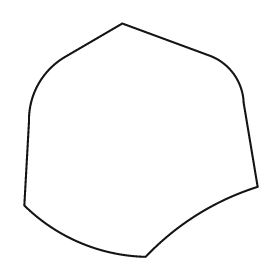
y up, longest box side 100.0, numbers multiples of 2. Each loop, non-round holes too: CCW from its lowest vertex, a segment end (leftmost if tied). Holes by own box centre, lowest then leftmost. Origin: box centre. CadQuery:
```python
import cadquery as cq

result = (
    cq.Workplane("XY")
    .moveTo(2.0, -50.0)
    .threePointArc((24.0, -32.0), (50.0, -20.0))
    .lineTo(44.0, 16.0)
    .threePointArc((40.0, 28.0), (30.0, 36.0))
    .lineTo(-8.0, 50.0)
    .lineTo(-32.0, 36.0)
    .threePointArc((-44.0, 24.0), (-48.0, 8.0))
    .lineTo(-50.0, -28.0)
    .threePointArc((-26.0, -44.0), (2.0, -50.0))
    .close()
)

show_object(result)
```